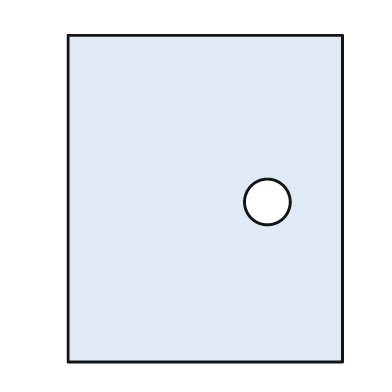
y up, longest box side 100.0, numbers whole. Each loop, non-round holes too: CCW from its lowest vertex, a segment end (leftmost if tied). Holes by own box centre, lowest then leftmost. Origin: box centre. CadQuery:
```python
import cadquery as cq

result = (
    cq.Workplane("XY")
    .moveTo(-42.0, -50.0)
    .lineTo(42.0, -50.0)
    .lineTo(42.0, 50.0)
    .lineTo(-42.0, 50.0)
    .close()
    .moveTo(19.0, -1.0)
    .circle(7.0)
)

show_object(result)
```